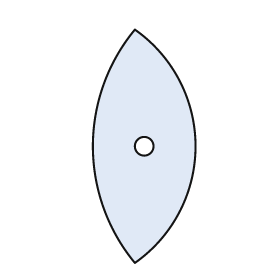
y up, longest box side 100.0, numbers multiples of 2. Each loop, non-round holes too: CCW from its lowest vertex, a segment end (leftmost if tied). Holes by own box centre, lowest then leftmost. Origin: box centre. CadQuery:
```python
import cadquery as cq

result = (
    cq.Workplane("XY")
    .moveTo(-4.0, -50.0)
    .threePointArc((22.0, 0.0), (-4.0, 50.0))
    .threePointArc((-22.0, 0.0), (-4.0, -50.0))
    .close()
    .moveTo(0.0, 0.0)
    .circle(4.0)
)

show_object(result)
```